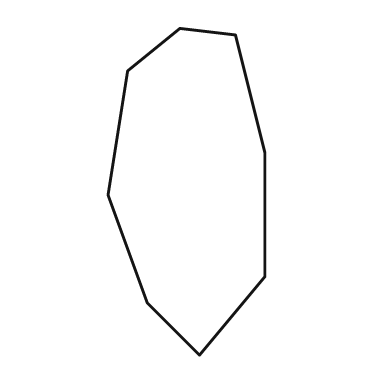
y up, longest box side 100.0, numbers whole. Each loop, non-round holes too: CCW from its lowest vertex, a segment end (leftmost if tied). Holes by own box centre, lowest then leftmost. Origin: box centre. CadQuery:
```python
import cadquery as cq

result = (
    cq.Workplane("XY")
    .moveTo(4.0, -50.0)
    .lineTo(24.0, -26.0)
    .lineTo(24.0, 12.0)
    .lineTo(15.0, 48.0)
    .lineTo(-2.0, 50.0)
    .lineTo(-18.0, 37.0)
    .lineTo(-24.0, -1.0)
    .lineTo(-12.0, -34.0)
    .close()
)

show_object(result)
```